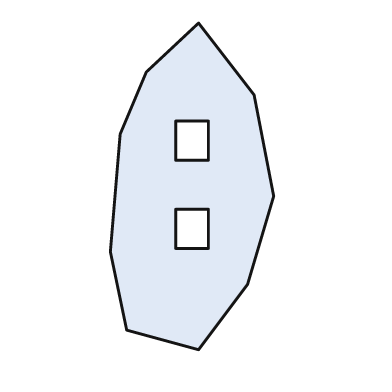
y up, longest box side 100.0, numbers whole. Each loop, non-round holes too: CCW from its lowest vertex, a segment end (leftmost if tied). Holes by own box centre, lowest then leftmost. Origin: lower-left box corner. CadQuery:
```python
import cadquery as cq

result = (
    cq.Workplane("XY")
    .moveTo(27.0, 0.0)
    .lineTo(42.0, 20.0)
    .lineTo(50.0, 47.0)
    .lineTo(44.0, 78.0)
    .lineTo(27.0, 100.0)
    .lineTo(11.0, 85.0)
    .lineTo(3.0, 66.0)
    .lineTo(0.0, 30.0)
    .lineTo(5.0, 6.0)
    .close()
    .moveTo(20.0, 31.0)
    .lineTo(30.0, 31.0)
    .lineTo(30.0, 43.0)
    .lineTo(20.0, 43.0)
    .close()
    .moveTo(20.0, 58.0)
    .lineTo(30.0, 58.0)
    .lineTo(30.0, 70.0)
    .lineTo(20.0, 70.0)
    .close()
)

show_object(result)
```